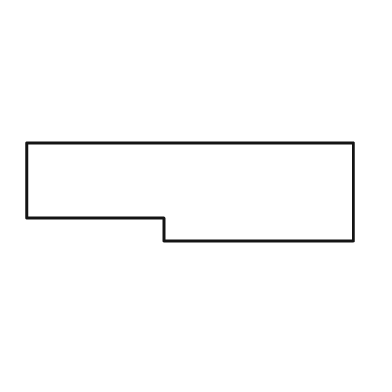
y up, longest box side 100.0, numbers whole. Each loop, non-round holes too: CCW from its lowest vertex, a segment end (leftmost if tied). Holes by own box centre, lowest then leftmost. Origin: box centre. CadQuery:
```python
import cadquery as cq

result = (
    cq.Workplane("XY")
    .moveTo(-8.0, -15.0)
    .lineTo(50.0, -15.0)
    .lineTo(50.0, 15.0)
    .lineTo(-50.0, 15.0)
    .lineTo(-50.0, -8.0)
    .lineTo(-8.0, -8.0)
    .close()
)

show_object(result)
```